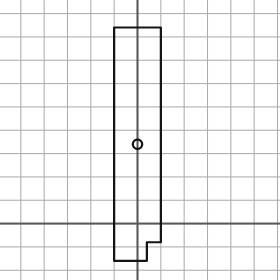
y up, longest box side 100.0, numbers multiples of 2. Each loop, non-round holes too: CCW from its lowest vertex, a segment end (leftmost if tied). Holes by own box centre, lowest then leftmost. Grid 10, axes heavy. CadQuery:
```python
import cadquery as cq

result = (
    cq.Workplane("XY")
    .moveTo(-10.0, -16.0)
    .lineTo(4.0, -16.0)
    .lineTo(4.0, -8.0)
    .lineTo(10.0, -8.0)
    .lineTo(10.0, 84.0)
    .lineTo(-10.0, 84.0)
    .close()
    .moveTo(0.0, 34.0)
    .circle(2.0)
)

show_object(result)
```